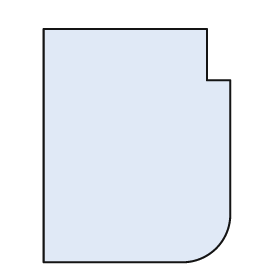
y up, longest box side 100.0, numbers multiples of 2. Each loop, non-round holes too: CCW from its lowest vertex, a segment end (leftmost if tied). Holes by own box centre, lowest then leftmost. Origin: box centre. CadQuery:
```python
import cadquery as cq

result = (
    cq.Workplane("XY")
    .moveTo(-40.0, -50.0)
    .lineTo(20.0, -50.0)
    .threePointArc((34.0, -44.0), (40.0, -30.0))
    .lineTo(40.0, 28.0)
    .lineTo(30.0, 28.0)
    .lineTo(30.0, 50.0)
    .lineTo(-40.0, 50.0)
    .close()
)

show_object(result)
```